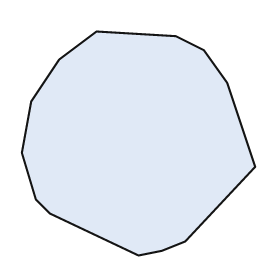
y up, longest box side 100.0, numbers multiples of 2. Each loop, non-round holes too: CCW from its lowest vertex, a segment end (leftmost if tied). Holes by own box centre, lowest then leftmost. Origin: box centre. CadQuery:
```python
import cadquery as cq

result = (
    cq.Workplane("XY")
    .moveTo(0.0, -48.0)
    .lineTo(10.0, -46.0)
    .lineTo(20.0, -42.0)
    .lineTo(50.0, -10.0)
    .lineTo(38.0, 26.0)
    .lineTo(28.0, 40.0)
    .lineTo(16.0, 46.0)
    .lineTo(-18.0, 48.0)
    .lineTo(-34.0, 36.0)
    .lineTo(-46.0, 18.0)
    .lineTo(-50.0, -4.0)
    .lineTo(-44.0, -24.0)
    .lineTo(-38.0, -30.0)
    .close()
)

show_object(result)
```